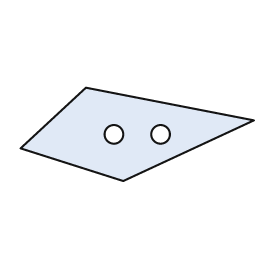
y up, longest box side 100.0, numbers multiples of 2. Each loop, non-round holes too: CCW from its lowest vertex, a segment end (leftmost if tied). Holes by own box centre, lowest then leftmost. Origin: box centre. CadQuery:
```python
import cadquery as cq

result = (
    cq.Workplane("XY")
    .moveTo(-6.0, -20.0)
    .lineTo(50.0, 6.0)
    .lineTo(-22.0, 20.0)
    .lineTo(-50.0, -6.0)
    .close()
    .moveTo(-10.0, 0.0)
    .circle(4.0)
    .moveTo(10.0, 0.0)
    .circle(4.0)
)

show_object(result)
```